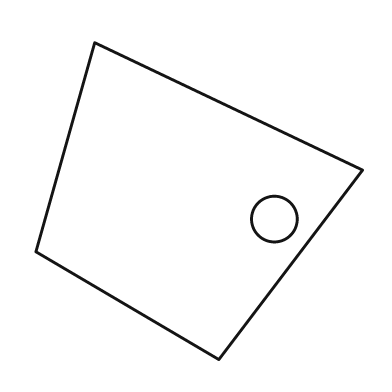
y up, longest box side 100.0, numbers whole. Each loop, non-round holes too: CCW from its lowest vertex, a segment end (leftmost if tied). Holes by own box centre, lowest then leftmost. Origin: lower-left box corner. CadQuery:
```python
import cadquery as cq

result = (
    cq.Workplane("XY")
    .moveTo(56.0, 0.0)
    .lineTo(100.0, 58.0)
    .lineTo(18.0, 97.0)
    .lineTo(0.0, 33.0)
    .close()
    .moveTo(73.0, 43.0)
    .circle(7.0)
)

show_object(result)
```